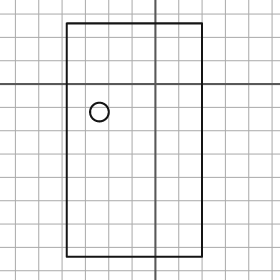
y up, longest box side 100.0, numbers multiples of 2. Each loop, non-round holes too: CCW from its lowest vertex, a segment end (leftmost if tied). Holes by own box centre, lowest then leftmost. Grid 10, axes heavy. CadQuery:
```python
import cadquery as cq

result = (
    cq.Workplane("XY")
    .moveTo(-38.0, -74.0)
    .lineTo(20.0, -74.0)
    .lineTo(20.0, 26.0)
    .lineTo(-38.0, 26.0)
    .close()
    .moveTo(-24.0, -12.0)
    .circle(4.0)
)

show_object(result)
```